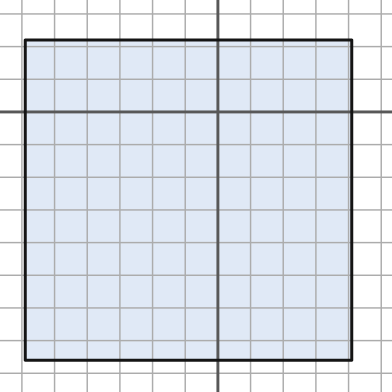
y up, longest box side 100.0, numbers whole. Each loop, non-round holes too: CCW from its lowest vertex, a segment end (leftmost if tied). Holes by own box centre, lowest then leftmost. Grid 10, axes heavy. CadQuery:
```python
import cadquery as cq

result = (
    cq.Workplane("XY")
    .moveTo(-59.0, -76.0)
    .lineTo(41.0, -76.0)
    .lineTo(41.0, 22.0)
    .lineTo(-59.0, 22.0)
    .close()
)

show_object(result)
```